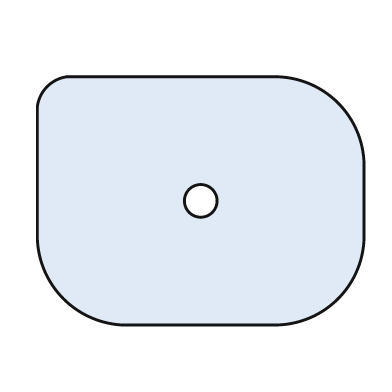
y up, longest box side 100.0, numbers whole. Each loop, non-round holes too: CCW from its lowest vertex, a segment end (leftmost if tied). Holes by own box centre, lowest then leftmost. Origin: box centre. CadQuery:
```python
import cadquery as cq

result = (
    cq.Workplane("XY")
    .moveTo(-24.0, -38.0)
    .lineTo(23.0, -38.0)
    .threePointArc((42.0, -30.0), (50.0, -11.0))
    .lineTo(50.0, 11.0)
    .threePointArc((42.0, 30.0), (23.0, 38.0))
    .lineTo(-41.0, 38.0)
    .threePointArc((-47.0, 35.0), (-50.0, 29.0))
    .lineTo(-50.0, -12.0)
    .threePointArc((-42.0, -30.0), (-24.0, -38.0))
    .close()
    .moveTo(0.0, 0.0)
    .circle(5.0)
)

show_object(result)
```